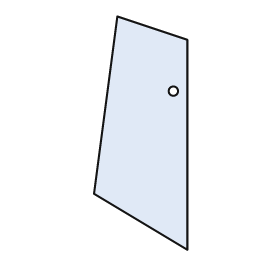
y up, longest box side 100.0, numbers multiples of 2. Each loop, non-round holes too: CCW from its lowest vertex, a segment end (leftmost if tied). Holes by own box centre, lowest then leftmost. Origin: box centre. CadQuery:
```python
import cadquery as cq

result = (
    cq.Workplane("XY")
    .moveTo(20.0, -50.0)
    .lineTo(20.0, 40.0)
    .lineTo(-10.0, 50.0)
    .lineTo(-20.0, -26.0)
    .close()
    .moveTo(14.0, 18.0)
    .circle(2.0)
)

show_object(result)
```